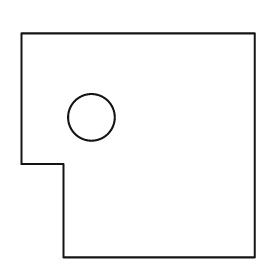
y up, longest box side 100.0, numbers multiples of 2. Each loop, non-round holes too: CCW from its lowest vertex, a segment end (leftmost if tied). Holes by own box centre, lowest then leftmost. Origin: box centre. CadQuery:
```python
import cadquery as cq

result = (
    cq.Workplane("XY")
    .moveTo(-32.0, -48.0)
    .lineTo(50.0, -48.0)
    .lineTo(50.0, 48.0)
    .lineTo(-50.0, 48.0)
    .lineTo(-50.0, -8.0)
    .lineTo(-32.0, -8.0)
    .close()
    .moveTo(-20.0, 12.0)
    .circle(10.0)
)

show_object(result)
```